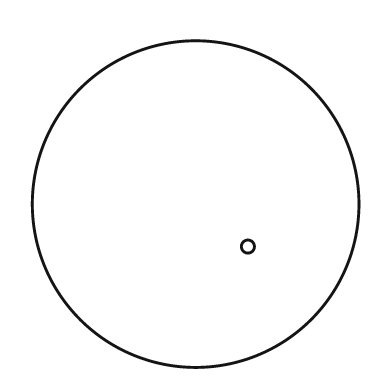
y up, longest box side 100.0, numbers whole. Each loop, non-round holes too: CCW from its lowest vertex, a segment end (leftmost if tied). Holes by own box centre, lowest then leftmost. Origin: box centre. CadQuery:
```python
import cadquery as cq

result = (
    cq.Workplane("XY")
    .moveTo(0.0, 0.0)
    .circle(50.0)
    .moveTo(16.0, -13.0)
    .circle(2.0)
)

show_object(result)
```